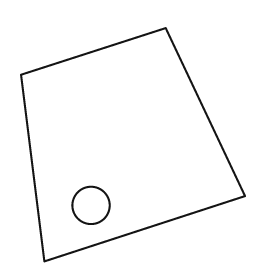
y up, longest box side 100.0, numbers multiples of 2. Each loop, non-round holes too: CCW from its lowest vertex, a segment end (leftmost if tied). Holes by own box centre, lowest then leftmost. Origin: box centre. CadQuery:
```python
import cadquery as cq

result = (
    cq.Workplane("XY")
    .moveTo(-38.0, -50.0)
    .lineTo(48.0, -22.0)
    .lineTo(14.0, 50.0)
    .lineTo(-48.0, 30.0)
    .close()
    .moveTo(-18.0, -26.0)
    .circle(8.0)
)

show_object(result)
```